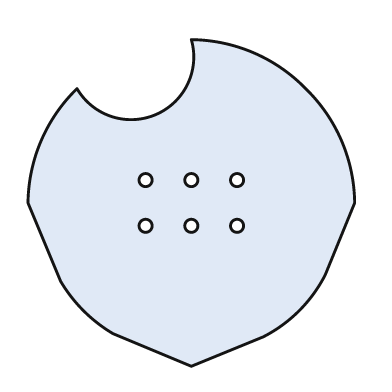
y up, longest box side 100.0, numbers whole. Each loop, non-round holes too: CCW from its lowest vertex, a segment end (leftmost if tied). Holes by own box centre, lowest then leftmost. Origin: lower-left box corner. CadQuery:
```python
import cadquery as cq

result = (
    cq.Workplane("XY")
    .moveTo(50.0, 0.0)
    .lineTo(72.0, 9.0)
    .threePointArc((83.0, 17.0), (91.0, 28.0))
    .lineTo(100.0, 50.0)
    .threePointArc((96.0, 69.0), (85.0, 85.0))
    .threePointArc((69.0, 96.0), (50.0, 100.0))
    .threePointArc((39.0, 77.0), (15.0, 85.0))
    .threePointArc((4.0, 69.0), (0.0, 50.0))
    .lineTo(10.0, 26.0)
    .threePointArc((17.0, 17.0), (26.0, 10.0))
    .close()
    .moveTo(36.0, 43.0)
    .circle(2.0)
    .moveTo(50.0, 43.0)
    .circle(2.0)
    .moveTo(64.0, 43.0)
    .circle(2.0)
    .moveTo(36.0, 57.0)
    .circle(2.0)
    .moveTo(50.0, 57.0)
    .circle(2.0)
    .moveTo(64.0, 57.0)
    .circle(2.0)
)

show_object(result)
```